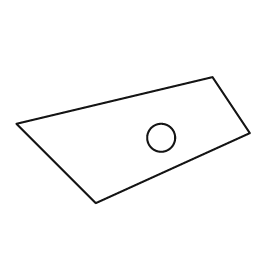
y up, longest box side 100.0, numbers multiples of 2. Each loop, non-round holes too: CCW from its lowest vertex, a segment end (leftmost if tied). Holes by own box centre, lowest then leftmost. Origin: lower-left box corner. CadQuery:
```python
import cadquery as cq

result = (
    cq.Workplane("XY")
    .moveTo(34.0, 0.0)
    .lineTo(100.0, 30.0)
    .lineTo(84.0, 54.0)
    .lineTo(0.0, 34.0)
    .close()
    .moveTo(62.0, 28.0)
    .circle(6.0)
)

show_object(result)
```